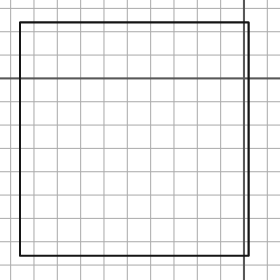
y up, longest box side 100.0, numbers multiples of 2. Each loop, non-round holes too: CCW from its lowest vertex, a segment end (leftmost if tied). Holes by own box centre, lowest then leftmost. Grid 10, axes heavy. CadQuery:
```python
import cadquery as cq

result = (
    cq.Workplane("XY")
    .moveTo(-96.0, -76.0)
    .lineTo(2.0, -76.0)
    .lineTo(2.0, 24.0)
    .lineTo(-96.0, 24.0)
    .close()
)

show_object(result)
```